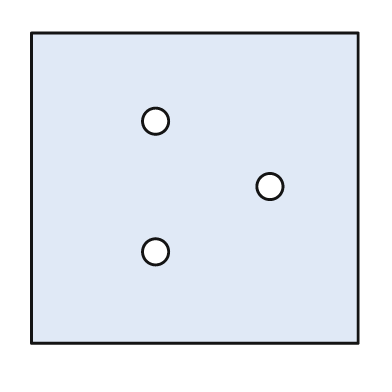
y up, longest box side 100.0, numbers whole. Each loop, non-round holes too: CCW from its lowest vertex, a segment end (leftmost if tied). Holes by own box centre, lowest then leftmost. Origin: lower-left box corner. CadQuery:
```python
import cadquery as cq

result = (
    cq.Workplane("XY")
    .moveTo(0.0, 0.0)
    .lineTo(100.0, 0.0)
    .lineTo(100.0, 95.0)
    .lineTo(0.0, 95.0)
    .close()
    .moveTo(38.0, 28.0)
    .circle(4.0)
    .moveTo(73.0, 48.0)
    .circle(4.0)
    .moveTo(38.0, 68.0)
    .circle(4.0)
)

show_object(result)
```